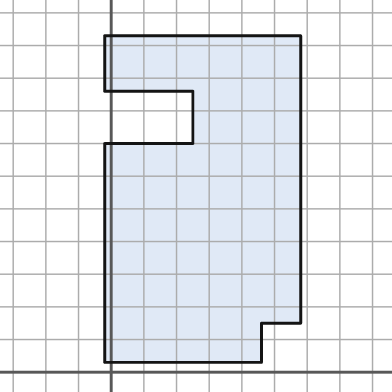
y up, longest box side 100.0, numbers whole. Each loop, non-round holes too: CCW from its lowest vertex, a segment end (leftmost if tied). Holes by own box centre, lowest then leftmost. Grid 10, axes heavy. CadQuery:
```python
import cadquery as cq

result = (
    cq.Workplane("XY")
    .moveTo(-2.0, 3.0)
    .lineTo(46.0, 3.0)
    .lineTo(46.0, 15.0)
    .lineTo(58.0, 15.0)
    .lineTo(58.0, 103.0)
    .lineTo(-2.0, 103.0)
    .lineTo(-2.0, 86.0)
    .lineTo(25.0, 86.0)
    .lineTo(25.0, 70.0)
    .lineTo(-2.0, 70.0)
    .close()
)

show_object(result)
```